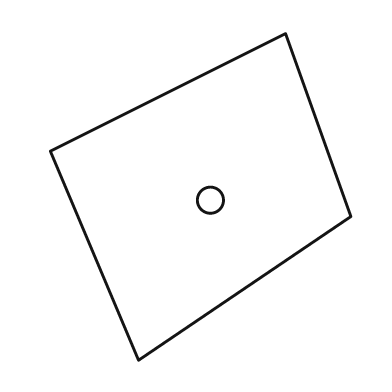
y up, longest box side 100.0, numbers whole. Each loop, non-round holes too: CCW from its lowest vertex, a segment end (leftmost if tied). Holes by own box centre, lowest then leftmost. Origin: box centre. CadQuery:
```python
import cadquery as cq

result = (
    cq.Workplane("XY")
    .moveTo(-19.0, -50.0)
    .lineTo(46.0, -6.0)
    .lineTo(26.0, 50.0)
    .lineTo(-46.0, 14.0)
    .close()
    .moveTo(3.0, -1.0)
    .circle(4.0)
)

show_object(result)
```